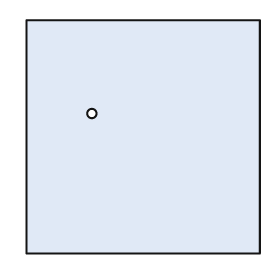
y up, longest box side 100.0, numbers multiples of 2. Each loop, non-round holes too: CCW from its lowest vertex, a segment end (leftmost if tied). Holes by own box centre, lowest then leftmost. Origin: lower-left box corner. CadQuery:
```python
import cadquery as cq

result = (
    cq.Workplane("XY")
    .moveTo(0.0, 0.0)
    .lineTo(100.0, 0.0)
    .lineTo(100.0, 100.0)
    .lineTo(0.0, 100.0)
    .close()
    .moveTo(28.0, 60.0)
    .circle(2.0)
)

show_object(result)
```